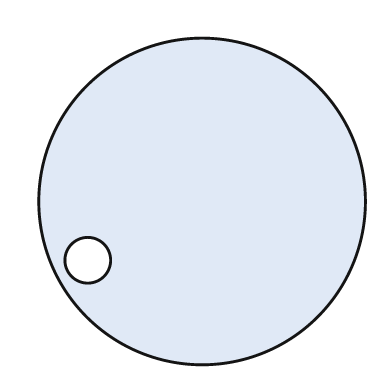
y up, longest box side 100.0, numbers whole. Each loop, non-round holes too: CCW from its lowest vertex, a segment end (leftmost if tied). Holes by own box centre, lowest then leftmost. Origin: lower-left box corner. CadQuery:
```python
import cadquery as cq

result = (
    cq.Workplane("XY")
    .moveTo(50.0, 50.0)
    .circle(50.0)
    .moveTo(15.0, 32.0)
    .circle(7.0)
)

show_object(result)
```